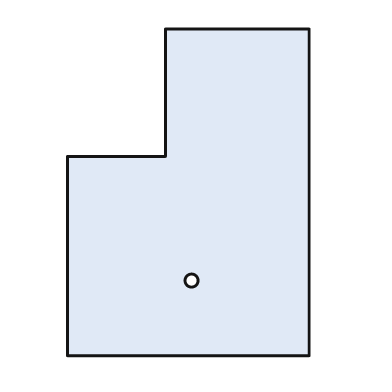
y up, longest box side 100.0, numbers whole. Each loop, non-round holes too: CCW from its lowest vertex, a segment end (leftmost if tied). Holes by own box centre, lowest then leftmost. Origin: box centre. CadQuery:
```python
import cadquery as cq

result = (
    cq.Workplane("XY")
    .moveTo(-37.0, -50.0)
    .lineTo(37.0, -50.0)
    .lineTo(37.0, 50.0)
    .lineTo(-7.0, 50.0)
    .lineTo(-7.0, 11.0)
    .lineTo(-37.0, 11.0)
    .close()
    .moveTo(1.0, -27.0)
    .circle(2.0)
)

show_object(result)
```